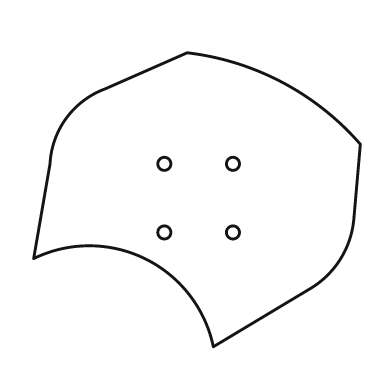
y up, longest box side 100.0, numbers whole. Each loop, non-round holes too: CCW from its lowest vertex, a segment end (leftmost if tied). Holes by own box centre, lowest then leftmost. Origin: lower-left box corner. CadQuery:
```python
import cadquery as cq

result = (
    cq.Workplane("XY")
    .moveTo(55.0, 0.0)
    .lineTo(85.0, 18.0)
    .threePointArc((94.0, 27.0), (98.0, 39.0))
    .lineTo(100.0, 62.0)
    .threePointArc((76.0, 81.0), (47.0, 90.0))
    .lineTo(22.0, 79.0)
    .threePointArc((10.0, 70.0), (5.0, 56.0))
    .lineTo(0.0, 27.0)
    .threePointArc((34.0, 27.0), (55.0, 0.0))
    .close()
    .moveTo(40.0, 35.0)
    .circle(2.0)
    .moveTo(61.0, 35.0)
    .circle(2.0)
    .moveTo(40.0, 56.0)
    .circle(2.0)
    .moveTo(61.0, 56.0)
    .circle(2.0)
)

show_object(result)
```